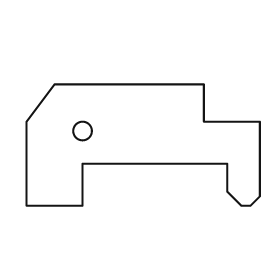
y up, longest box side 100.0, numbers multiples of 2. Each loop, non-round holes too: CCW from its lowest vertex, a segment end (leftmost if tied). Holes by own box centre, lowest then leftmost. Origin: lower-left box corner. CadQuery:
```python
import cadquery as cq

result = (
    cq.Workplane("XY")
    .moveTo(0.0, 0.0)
    .lineTo(24.0, 0.0)
    .lineTo(24.0, 18.0)
    .lineTo(86.0, 18.0)
    .lineTo(86.0, 6.0)
    .lineTo(92.0, 0.0)
    .lineTo(96.0, 0.0)
    .lineTo(100.0, 4.0)
    .lineTo(100.0, 36.0)
    .lineTo(76.0, 36.0)
    .lineTo(76.0, 52.0)
    .lineTo(12.0, 52.0)
    .lineTo(0.0, 36.0)
    .close()
    .moveTo(24.0, 32.0)
    .circle(4.0)
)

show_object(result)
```